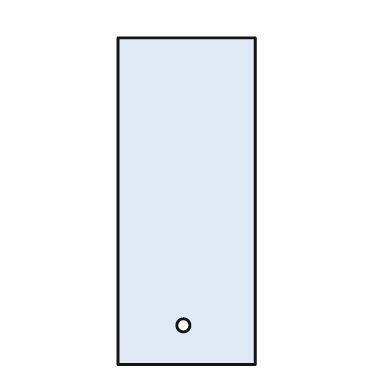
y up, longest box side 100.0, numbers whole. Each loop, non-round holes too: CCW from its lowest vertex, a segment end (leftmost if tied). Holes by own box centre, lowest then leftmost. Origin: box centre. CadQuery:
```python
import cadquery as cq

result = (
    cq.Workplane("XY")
    .moveTo(-21.0, -50.0)
    .lineTo(21.0, -50.0)
    .lineTo(21.0, 50.0)
    .lineTo(-21.0, 50.0)
    .close()
    .moveTo(-1.0, -38.0)
    .circle(2.0)
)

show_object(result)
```